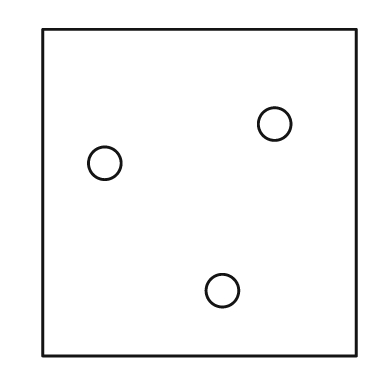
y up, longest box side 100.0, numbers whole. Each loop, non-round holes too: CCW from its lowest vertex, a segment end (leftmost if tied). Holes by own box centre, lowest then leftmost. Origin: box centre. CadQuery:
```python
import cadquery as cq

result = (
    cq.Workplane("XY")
    .moveTo(-48.0, -50.0)
    .lineTo(48.0, -50.0)
    .lineTo(48.0, 50.0)
    .lineTo(-48.0, 50.0)
    .close()
    .moveTo(7.0, -30.0)
    .circle(5.0)
    .moveTo(-29.0, 9.0)
    .circle(5.0)
    .moveTo(23.0, 21.0)
    .circle(5.0)
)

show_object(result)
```